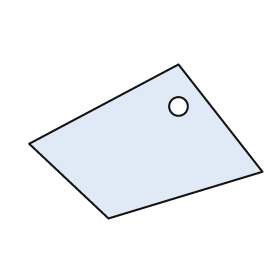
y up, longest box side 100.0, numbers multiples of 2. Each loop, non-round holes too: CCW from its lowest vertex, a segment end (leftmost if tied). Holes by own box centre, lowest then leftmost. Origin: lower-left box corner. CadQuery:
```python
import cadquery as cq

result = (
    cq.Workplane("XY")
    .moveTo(34.0, 0.0)
    .lineTo(100.0, 20.0)
    .lineTo(64.0, 66.0)
    .lineTo(0.0, 32.0)
    .close()
    .moveTo(64.0, 48.0)
    .circle(4.0)
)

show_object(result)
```